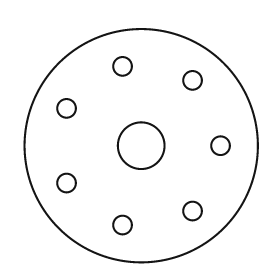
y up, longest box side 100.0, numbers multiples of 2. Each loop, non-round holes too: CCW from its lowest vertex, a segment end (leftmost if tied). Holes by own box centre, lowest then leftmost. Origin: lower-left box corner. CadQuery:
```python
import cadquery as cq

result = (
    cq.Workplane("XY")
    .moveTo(50.0, 50.0)
    .circle(50.0)
    .moveTo(42.0, 16.0)
    .circle(4.0)
    .moveTo(72.0, 22.0)
    .circle(4.0)
    .moveTo(18.0, 34.0)
    .circle(4.0)
    .moveTo(50.0, 50.0)
    .circle(10.0)
    .moveTo(84.0, 50.0)
    .circle(4.0)
    .moveTo(18.0, 66.0)
    .circle(4.0)
    .moveTo(72.0, 78.0)
    .circle(4.0)
    .moveTo(42.0, 84.0)
    .circle(4.0)
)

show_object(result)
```